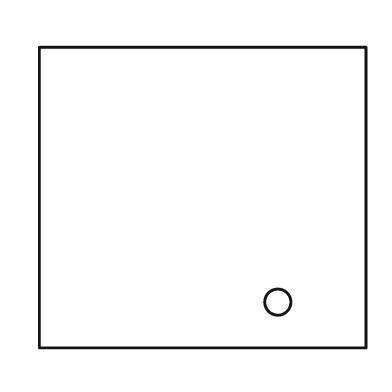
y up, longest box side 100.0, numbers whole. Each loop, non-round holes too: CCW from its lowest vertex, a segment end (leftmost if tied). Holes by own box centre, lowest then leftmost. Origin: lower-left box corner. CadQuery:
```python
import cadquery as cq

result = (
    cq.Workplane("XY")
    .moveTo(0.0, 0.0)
    .lineTo(100.0, 0.0)
    .lineTo(100.0, 92.0)
    .lineTo(0.0, 92.0)
    .close()
    .moveTo(73.0, 14.0)
    .circle(4.0)
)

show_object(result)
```